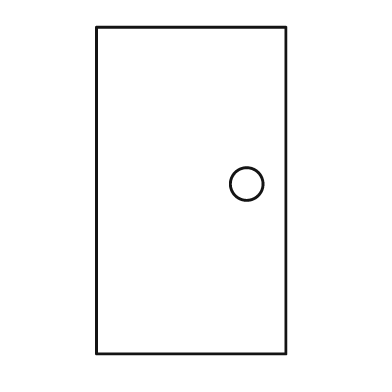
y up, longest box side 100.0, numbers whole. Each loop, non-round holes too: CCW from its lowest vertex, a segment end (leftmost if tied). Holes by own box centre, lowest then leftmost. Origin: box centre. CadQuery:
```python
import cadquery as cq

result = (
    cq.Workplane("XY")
    .moveTo(-29.0, -50.0)
    .lineTo(29.0, -50.0)
    .lineTo(29.0, 50.0)
    .lineTo(-29.0, 50.0)
    .close()
    .moveTo(17.0, 2.0)
    .circle(5.0)
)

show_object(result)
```